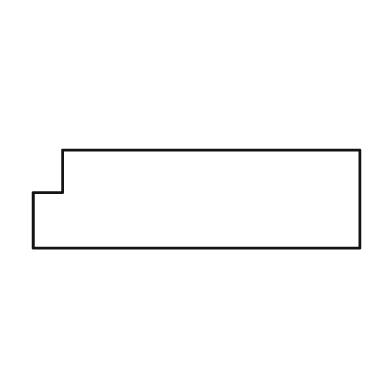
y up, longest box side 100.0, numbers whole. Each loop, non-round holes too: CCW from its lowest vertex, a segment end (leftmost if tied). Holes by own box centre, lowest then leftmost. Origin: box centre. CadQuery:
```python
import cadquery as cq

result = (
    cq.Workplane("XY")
    .moveTo(-50.0, -15.0)
    .lineTo(50.0, -15.0)
    .lineTo(50.0, 15.0)
    .lineTo(-41.0, 15.0)
    .lineTo(-41.0, 2.0)
    .lineTo(-50.0, 2.0)
    .close()
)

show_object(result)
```